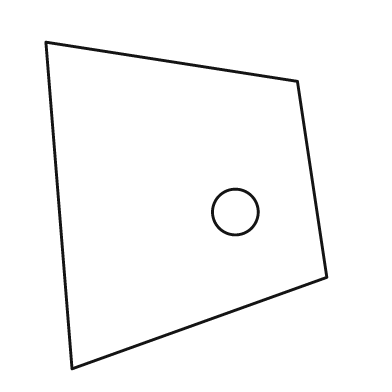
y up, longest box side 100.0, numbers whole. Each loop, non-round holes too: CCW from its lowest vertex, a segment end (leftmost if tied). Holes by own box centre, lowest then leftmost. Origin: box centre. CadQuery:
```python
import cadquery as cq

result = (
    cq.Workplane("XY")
    .moveTo(-35.0, -50.0)
    .lineTo(43.0, -22.0)
    .lineTo(34.0, 38.0)
    .lineTo(-43.0, 50.0)
    .close()
    .moveTo(15.0, -2.0)
    .circle(7.0)
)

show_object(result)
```